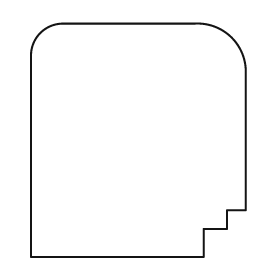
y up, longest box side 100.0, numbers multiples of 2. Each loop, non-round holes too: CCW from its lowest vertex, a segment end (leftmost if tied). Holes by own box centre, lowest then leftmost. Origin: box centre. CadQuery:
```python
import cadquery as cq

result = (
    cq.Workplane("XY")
    .moveTo(-46.0, -50.0)
    .lineTo(28.0, -50.0)
    .lineTo(28.0, -38.0)
    .lineTo(38.0, -38.0)
    .lineTo(38.0, -30.0)
    .lineTo(46.0, -30.0)
    .lineTo(46.0, 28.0)
    .threePointArc((40.0, 44.0), (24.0, 50.0))
    .lineTo(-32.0, 50.0)
    .threePointArc((-42.0, 46.0), (-46.0, 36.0))
    .close()
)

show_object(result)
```